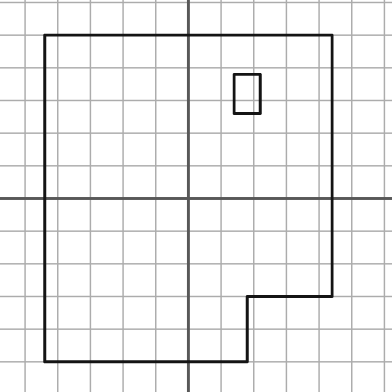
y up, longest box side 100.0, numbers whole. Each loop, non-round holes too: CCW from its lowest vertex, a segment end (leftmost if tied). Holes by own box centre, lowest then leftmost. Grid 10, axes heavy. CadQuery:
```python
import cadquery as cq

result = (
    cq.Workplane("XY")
    .moveTo(-44.0, -50.0)
    .lineTo(18.0, -50.0)
    .lineTo(18.0, -30.0)
    .lineTo(44.0, -30.0)
    .lineTo(44.0, 50.0)
    .lineTo(-44.0, 50.0)
    .close()
    .moveTo(14.0, 26.0)
    .lineTo(22.0, 26.0)
    .lineTo(22.0, 38.0)
    .lineTo(14.0, 38.0)
    .close()
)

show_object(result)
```